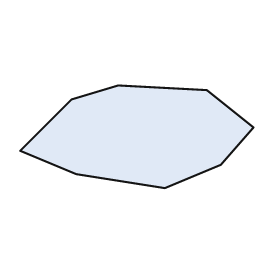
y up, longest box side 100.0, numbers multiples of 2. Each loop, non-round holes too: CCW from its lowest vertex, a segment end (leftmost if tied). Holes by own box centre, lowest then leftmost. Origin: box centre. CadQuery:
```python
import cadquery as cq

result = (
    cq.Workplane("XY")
    .moveTo(12.0, -22.0)
    .lineTo(36.0, -12.0)
    .lineTo(50.0, 4.0)
    .lineTo(30.0, 20.0)
    .lineTo(-8.0, 22.0)
    .lineTo(-28.0, 16.0)
    .lineTo(-50.0, -6.0)
    .lineTo(-26.0, -16.0)
    .close()
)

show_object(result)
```